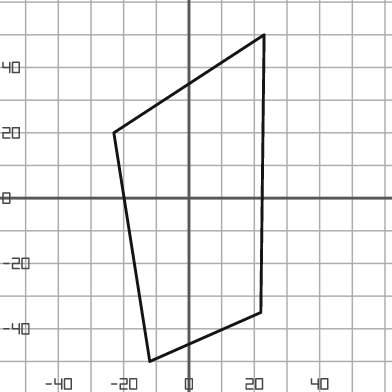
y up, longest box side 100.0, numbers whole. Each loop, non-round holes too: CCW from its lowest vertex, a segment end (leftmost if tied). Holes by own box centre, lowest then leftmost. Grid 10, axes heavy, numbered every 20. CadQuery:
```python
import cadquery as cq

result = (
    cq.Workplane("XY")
    .moveTo(-12.0, -50.0)
    .lineTo(22.0, -35.0)
    .lineTo(23.0, 50.0)
    .lineTo(-23.0, 20.0)
    .close()
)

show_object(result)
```